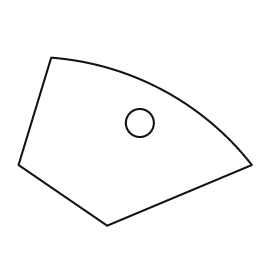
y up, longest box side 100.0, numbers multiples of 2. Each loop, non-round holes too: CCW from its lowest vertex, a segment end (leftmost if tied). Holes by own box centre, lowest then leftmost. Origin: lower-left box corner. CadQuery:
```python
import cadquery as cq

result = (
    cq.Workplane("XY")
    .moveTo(38.0, 0.0)
    .lineTo(100.0, 26.0)
    .threePointArc((62.0, 58.0), (14.0, 72.0))
    .lineTo(0.0, 26.0)
    .close()
    .moveTo(52.0, 44.0)
    .circle(6.0)
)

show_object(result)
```